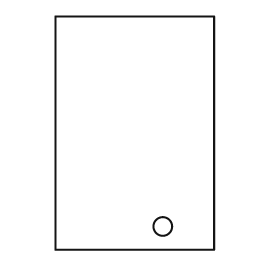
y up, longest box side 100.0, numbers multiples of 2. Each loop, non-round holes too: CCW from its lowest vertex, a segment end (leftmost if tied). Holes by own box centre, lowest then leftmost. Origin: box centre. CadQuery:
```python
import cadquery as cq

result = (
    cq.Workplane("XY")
    .moveTo(-34.0, -50.0)
    .lineTo(34.0, -50.0)
    .lineTo(34.0, 50.0)
    .lineTo(-34.0, 50.0)
    .close()
    .moveTo(12.0, -40.0)
    .circle(4.0)
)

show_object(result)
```